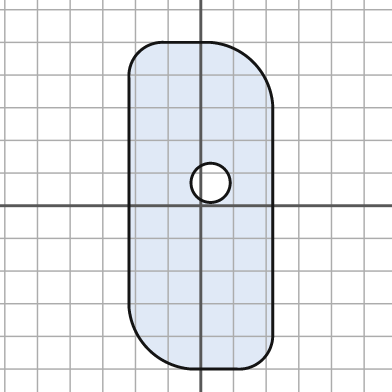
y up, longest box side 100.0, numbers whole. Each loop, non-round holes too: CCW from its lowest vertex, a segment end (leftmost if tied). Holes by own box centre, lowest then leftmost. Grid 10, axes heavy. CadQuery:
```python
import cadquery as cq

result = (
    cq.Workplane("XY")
    .moveTo(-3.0, -50.0)
    .lineTo(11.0, -50.0)
    .threePointArc((19.0, -47.0), (22.0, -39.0))
    .lineTo(22.0, 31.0)
    .threePointArc((16.0, 44.0), (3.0, 50.0))
    .lineTo(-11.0, 50.0)
    .threePointArc((-19.0, 47.0), (-22.0, 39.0))
    .lineTo(-22.0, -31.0)
    .threePointArc((-16.0, -44.0), (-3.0, -50.0))
    .close()
    .moveTo(3.0, 7.0)
    .circle(6.0)
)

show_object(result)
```